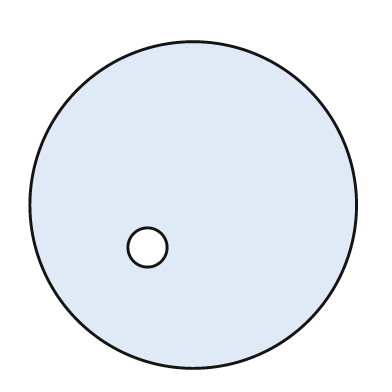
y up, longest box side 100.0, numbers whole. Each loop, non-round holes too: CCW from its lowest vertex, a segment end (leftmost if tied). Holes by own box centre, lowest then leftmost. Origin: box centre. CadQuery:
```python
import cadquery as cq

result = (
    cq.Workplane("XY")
    .moveTo(0.0, 0.0)
    .circle(50.0)
    .moveTo(-14.0, -13.0)
    .circle(6.0)
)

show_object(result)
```